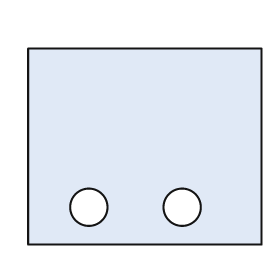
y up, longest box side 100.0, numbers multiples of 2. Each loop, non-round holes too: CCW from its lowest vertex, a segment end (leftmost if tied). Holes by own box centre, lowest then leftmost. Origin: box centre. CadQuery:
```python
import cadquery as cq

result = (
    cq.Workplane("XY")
    .moveTo(-50.0, -42.0)
    .lineTo(50.0, -42.0)
    .lineTo(50.0, 42.0)
    .lineTo(-50.0, 42.0)
    .close()
    .moveTo(-24.0, -26.0)
    .circle(8.0)
    .moveTo(16.0, -26.0)
    .circle(8.0)
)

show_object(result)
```